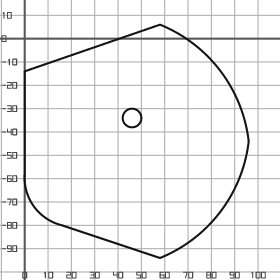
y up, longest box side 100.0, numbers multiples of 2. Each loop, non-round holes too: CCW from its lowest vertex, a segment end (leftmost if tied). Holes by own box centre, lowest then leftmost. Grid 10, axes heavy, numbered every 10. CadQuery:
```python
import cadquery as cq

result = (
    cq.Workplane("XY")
    .moveTo(58.0, -94.0)
    .threePointArc((84.0, -74.0), (96.0, -44.0))
    .threePointArc((84.0, -14.0), (58.0, 6.0))
    .lineTo(0.0, -14.0)
    .lineTo(0.0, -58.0)
    .threePointArc((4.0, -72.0), (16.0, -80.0))
    .close()
    .moveTo(46.0, -34.0)
    .circle(4.0)
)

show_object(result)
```